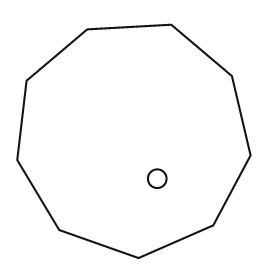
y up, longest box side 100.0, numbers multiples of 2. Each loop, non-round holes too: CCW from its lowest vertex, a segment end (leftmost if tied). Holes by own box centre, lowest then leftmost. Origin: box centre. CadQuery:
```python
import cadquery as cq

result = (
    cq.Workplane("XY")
    .moveTo(2.0, -50.0)
    .lineTo(34.0, -36.0)
    .lineTo(50.0, -6.0)
    .lineTo(42.0, 28.0)
    .lineTo(16.0, 50.0)
    .lineTo(-20.0, 48.0)
    .lineTo(-46.0, 26.0)
    .lineTo(-50.0, -8.0)
    .lineTo(-32.0, -38.0)
    .close()
    .moveTo(10.0, -16.0)
    .circle(4.0)
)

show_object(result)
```